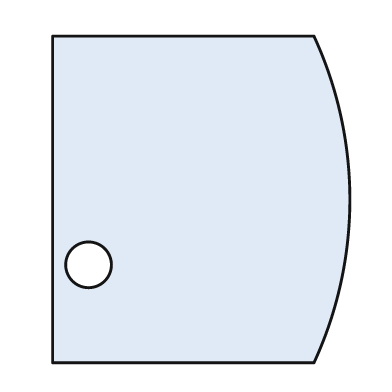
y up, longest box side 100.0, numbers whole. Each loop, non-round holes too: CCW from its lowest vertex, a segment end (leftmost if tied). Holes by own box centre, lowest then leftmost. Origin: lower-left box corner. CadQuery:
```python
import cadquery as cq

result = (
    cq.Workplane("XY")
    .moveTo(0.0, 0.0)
    .lineTo(80.0, 0.0)
    .threePointArc((91.0, 50.0), (80.0, 100.0))
    .lineTo(0.0, 100.0)
    .close()
    .moveTo(11.0, 30.0)
    .circle(7.0)
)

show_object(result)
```